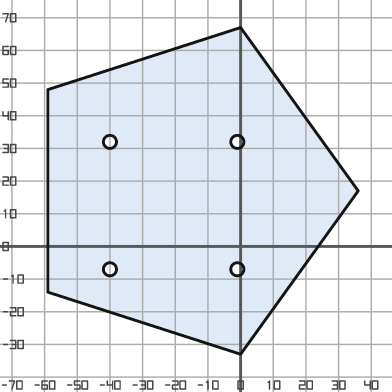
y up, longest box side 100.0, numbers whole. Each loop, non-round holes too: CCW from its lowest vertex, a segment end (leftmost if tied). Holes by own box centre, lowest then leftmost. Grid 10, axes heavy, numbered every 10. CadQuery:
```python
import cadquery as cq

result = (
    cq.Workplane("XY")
    .moveTo(0.0, -33.0)
    .lineTo(36.0, 17.0)
    .lineTo(0.0, 67.0)
    .lineTo(-59.0, 48.0)
    .lineTo(-59.0, -14.0)
    .close()
    .moveTo(-40.0, -7.0)
    .circle(2.0)
    .moveTo(-1.0, -7.0)
    .circle(2.0)
    .moveTo(-40.0, 32.0)
    .circle(2.0)
    .moveTo(-1.0, 32.0)
    .circle(2.0)
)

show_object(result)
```